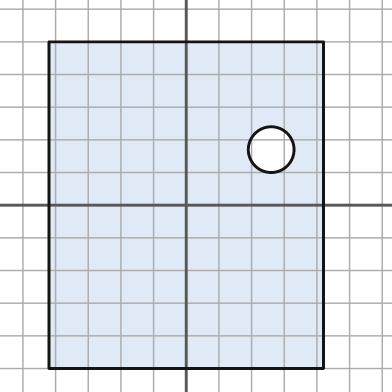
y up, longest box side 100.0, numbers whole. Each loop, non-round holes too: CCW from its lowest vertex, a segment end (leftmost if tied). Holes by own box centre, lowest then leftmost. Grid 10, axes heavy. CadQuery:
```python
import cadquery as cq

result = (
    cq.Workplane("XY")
    .moveTo(-42.0, -50.0)
    .lineTo(42.0, -50.0)
    .lineTo(42.0, 50.0)
    .lineTo(-42.0, 50.0)
    .close()
    .moveTo(26.0, 17.0)
    .circle(7.0)
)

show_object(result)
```